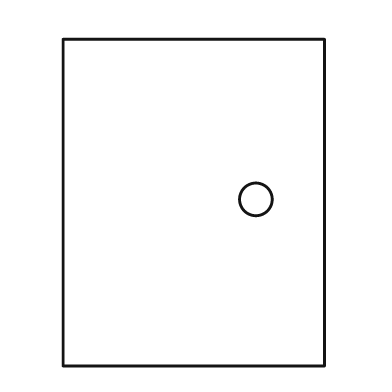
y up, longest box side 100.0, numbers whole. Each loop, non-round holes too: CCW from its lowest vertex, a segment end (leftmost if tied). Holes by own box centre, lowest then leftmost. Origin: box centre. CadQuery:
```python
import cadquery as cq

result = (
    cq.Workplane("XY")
    .moveTo(-40.0, -50.0)
    .lineTo(40.0, -50.0)
    .lineTo(40.0, 50.0)
    .lineTo(-40.0, 50.0)
    .close()
    .moveTo(19.0, 1.0)
    .circle(5.0)
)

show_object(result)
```